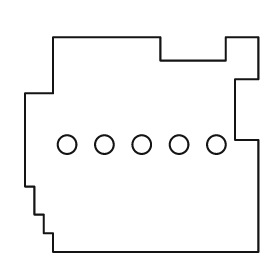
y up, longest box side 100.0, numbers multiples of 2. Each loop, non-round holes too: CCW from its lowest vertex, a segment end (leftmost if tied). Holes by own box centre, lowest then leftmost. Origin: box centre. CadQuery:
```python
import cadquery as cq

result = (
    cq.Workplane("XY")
    .moveTo(-38.0, -46.0)
    .lineTo(50.0, -46.0)
    .lineTo(50.0, 2.0)
    .lineTo(40.0, 2.0)
    .lineTo(40.0, 28.0)
    .lineTo(50.0, 28.0)
    .lineTo(50.0, 46.0)
    .lineTo(36.0, 46.0)
    .lineTo(36.0, 36.0)
    .lineTo(8.0, 36.0)
    .lineTo(8.0, 46.0)
    .lineTo(-38.0, 46.0)
    .lineTo(-38.0, 22.0)
    .lineTo(-50.0, 22.0)
    .lineTo(-50.0, -18.0)
    .lineTo(-46.0, -18.0)
    .lineTo(-46.0, -30.0)
    .lineTo(-42.0, -30.0)
    .lineTo(-42.0, -38.0)
    .lineTo(-38.0, -38.0)
    .close()
    .moveTo(-32.0, 0.0)
    .circle(4.0)
    .moveTo(-16.0, 0.0)
    .circle(4.0)
    .moveTo(0.0, 0.0)
    .circle(4.0)
    .moveTo(16.0, 0.0)
    .circle(4.0)
    .moveTo(32.0, 0.0)
    .circle(4.0)
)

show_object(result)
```